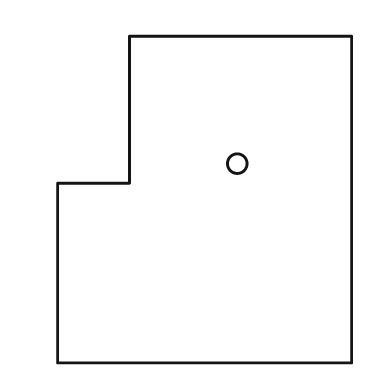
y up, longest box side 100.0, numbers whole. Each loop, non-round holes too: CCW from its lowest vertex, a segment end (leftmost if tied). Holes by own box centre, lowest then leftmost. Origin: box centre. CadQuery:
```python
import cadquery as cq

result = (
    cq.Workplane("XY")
    .moveTo(-45.0, -50.0)
    .lineTo(45.0, -50.0)
    .lineTo(45.0, 50.0)
    .lineTo(-23.0, 50.0)
    .lineTo(-23.0, 5.0)
    .lineTo(-45.0, 5.0)
    .close()
    .moveTo(10.0, 11.0)
    .circle(3.0)
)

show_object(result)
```